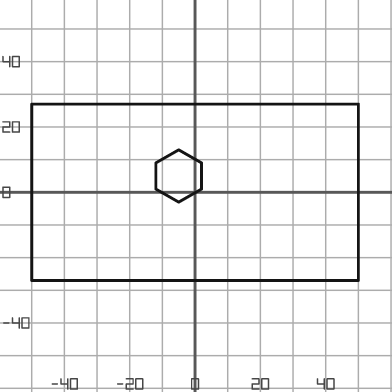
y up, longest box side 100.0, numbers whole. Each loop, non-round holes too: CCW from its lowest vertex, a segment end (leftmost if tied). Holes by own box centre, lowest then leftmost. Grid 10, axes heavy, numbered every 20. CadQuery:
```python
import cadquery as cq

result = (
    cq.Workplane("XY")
    .moveTo(-50.0, -27.0)
    .lineTo(50.0, -27.0)
    .lineTo(50.0, 27.0)
    .lineTo(-50.0, 27.0)
    .close()
    .moveTo(-5.0, -3.0)
    .lineTo(2.0, 1.0)
    .lineTo(2.0, 9.0)
    .lineTo(-5.0, 13.0)
    .lineTo(-12.0, 9.0)
    .lineTo(-12.0, 1.0)
    .close()
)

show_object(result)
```